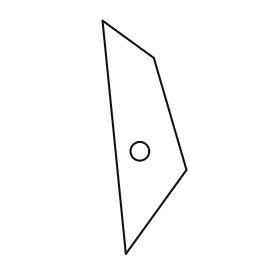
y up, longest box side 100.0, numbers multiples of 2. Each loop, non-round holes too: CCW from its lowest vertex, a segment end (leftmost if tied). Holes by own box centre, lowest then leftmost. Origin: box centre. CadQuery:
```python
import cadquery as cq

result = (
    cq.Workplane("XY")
    .moveTo(-8.0, -50.0)
    .lineTo(18.0, -14.0)
    .lineTo(4.0, 34.0)
    .lineTo(-18.0, 50.0)
    .close()
    .moveTo(-2.0, -6.0)
    .circle(4.0)
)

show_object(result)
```